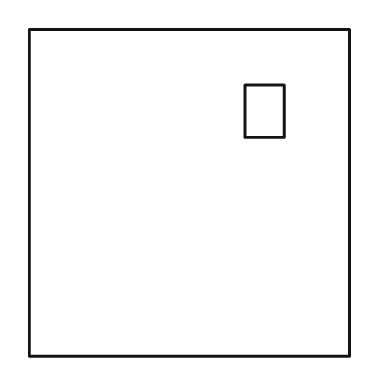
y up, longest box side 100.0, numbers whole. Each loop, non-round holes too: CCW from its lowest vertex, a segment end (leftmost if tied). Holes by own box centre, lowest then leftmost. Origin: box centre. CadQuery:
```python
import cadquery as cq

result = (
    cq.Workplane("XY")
    .moveTo(-49.0, -50.0)
    .lineTo(49.0, -50.0)
    .lineTo(49.0, 50.0)
    .lineTo(-49.0, 50.0)
    .close()
    .moveTo(17.0, 17.0)
    .lineTo(29.0, 17.0)
    .lineTo(29.0, 33.0)
    .lineTo(17.0, 33.0)
    .close()
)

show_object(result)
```